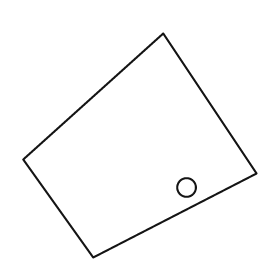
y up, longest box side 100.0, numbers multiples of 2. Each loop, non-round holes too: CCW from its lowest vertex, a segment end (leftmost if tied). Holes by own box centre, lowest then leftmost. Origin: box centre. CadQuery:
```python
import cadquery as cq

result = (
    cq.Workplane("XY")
    .moveTo(-20.0, -48.0)
    .lineTo(50.0, -12.0)
    .lineTo(10.0, 48.0)
    .lineTo(-50.0, -6.0)
    .close()
    .moveTo(20.0, -18.0)
    .circle(4.0)
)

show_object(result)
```